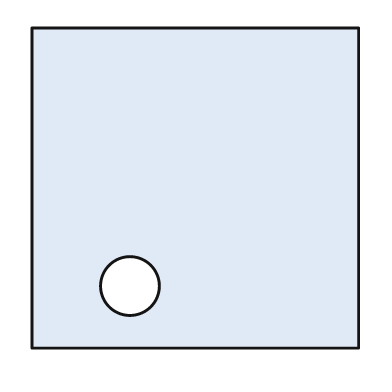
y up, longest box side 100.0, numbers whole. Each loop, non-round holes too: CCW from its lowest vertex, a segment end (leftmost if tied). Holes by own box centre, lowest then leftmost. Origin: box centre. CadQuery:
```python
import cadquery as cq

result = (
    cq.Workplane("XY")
    .moveTo(-50.0, -49.0)
    .lineTo(50.0, -49.0)
    .lineTo(50.0, 49.0)
    .lineTo(-50.0, 49.0)
    .close()
    .moveTo(-20.0, -30.0)
    .circle(9.0)
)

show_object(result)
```